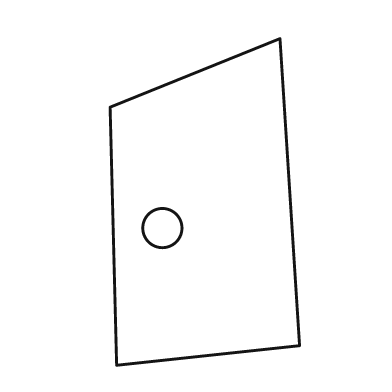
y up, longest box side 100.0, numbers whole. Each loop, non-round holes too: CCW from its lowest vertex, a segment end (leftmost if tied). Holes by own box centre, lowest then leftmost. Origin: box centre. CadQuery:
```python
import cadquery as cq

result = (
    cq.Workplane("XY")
    .moveTo(-27.0, -50.0)
    .lineTo(29.0, -44.0)
    .lineTo(23.0, 50.0)
    .lineTo(-29.0, 29.0)
    .close()
    .moveTo(-13.0, -8.0)
    .circle(6.0)
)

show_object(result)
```